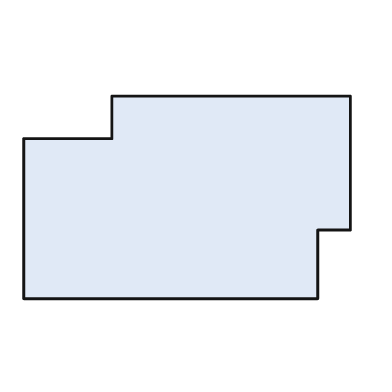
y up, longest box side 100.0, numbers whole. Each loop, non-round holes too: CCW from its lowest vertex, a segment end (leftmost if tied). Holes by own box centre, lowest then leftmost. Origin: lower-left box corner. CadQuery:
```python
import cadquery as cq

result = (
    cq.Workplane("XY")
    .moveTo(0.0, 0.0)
    .lineTo(90.0, 0.0)
    .lineTo(90.0, 21.0)
    .lineTo(100.0, 21.0)
    .lineTo(100.0, 62.0)
    .lineTo(27.0, 62.0)
    .lineTo(27.0, 49.0)
    .lineTo(0.0, 49.0)
    .close()
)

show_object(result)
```